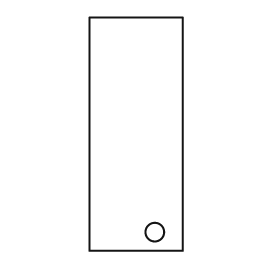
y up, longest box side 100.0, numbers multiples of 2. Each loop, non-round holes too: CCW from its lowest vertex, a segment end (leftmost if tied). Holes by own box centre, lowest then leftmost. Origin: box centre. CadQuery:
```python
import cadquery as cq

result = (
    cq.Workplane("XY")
    .moveTo(-20.0, -50.0)
    .lineTo(20.0, -50.0)
    .lineTo(20.0, 50.0)
    .lineTo(-20.0, 50.0)
    .close()
    .moveTo(8.0, -42.0)
    .circle(4.0)
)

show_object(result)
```